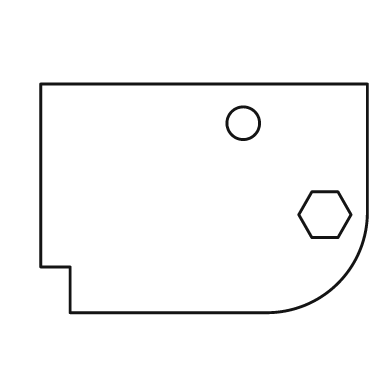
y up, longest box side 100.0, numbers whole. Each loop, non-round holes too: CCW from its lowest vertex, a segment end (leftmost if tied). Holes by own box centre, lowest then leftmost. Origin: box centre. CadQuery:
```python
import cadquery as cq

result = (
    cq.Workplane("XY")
    .moveTo(-41.0, -35.0)
    .lineTo(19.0, -35.0)
    .threePointArc((41.0, -26.0), (50.0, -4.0))
    .lineTo(50.0, 35.0)
    .lineTo(-50.0, 35.0)
    .lineTo(-50.0, -21.0)
    .lineTo(-41.0, -21.0)
    .close()
    .moveTo(33.0, -12.0)
    .lineTo(41.0, -12.0)
    .lineTo(45.0, -5.0)
    .lineTo(41.0, 2.0)
    .lineTo(33.0, 2.0)
    .lineTo(29.0, -5.0)
    .close()
    .moveTo(12.0, 23.0)
    .circle(5.0)
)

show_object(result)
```